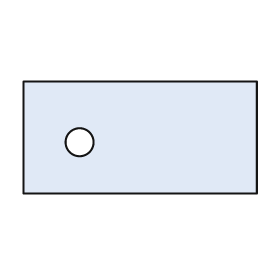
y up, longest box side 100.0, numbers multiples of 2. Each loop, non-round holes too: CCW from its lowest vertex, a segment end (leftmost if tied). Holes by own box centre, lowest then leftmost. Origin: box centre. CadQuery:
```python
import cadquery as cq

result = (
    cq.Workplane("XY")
    .moveTo(-50.0, -24.0)
    .lineTo(50.0, -24.0)
    .lineTo(50.0, 24.0)
    .lineTo(-50.0, 24.0)
    .close()
    .moveTo(-26.0, -2.0)
    .circle(6.0)
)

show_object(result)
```